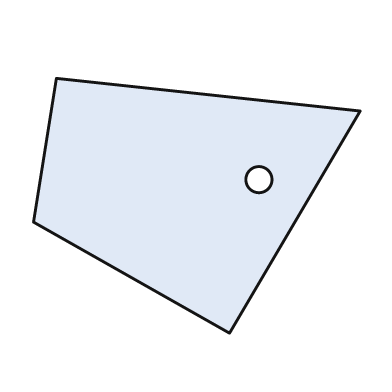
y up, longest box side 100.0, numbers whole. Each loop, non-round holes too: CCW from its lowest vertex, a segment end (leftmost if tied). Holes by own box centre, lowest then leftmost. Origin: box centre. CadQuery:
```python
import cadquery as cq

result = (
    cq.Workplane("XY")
    .moveTo(10.0, -39.0)
    .lineTo(50.0, 29.0)
    .lineTo(-43.0, 39.0)
    .lineTo(-50.0, -5.0)
    .close()
    .moveTo(19.0, 8.0)
    .circle(4.0)
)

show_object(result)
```